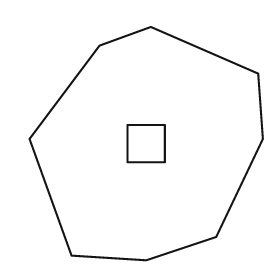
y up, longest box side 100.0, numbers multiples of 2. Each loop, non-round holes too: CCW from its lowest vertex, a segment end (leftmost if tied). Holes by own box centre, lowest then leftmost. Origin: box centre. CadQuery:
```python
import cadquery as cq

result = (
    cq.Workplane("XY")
    .moveTo(0.0, -50.0)
    .lineTo(30.0, -40.0)
    .lineTo(50.0, 2.0)
    .lineTo(48.0, 30.0)
    .lineTo(2.0, 50.0)
    .lineTo(-20.0, 42.0)
    .lineTo(-50.0, 2.0)
    .lineTo(-32.0, -48.0)
    .close()
    .moveTo(-8.0, -8.0)
    .lineTo(8.0, -8.0)
    .lineTo(8.0, 8.0)
    .lineTo(-8.0, 8.0)
    .close()
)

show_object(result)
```